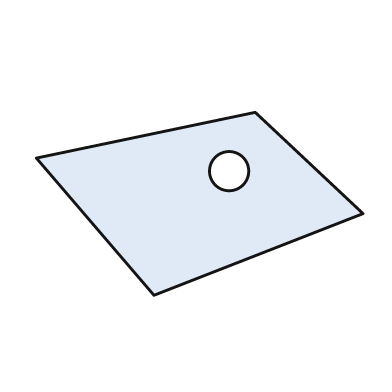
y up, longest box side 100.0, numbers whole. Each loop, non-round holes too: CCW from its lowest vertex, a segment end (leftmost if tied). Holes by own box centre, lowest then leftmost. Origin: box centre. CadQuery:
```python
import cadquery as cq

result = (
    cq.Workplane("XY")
    .moveTo(-14.0, -28.0)
    .lineTo(50.0, -3.0)
    .lineTo(17.0, 28.0)
    .lineTo(-50.0, 14.0)
    .close()
    .moveTo(9.0, 10.0)
    .circle(6.0)
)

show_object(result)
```